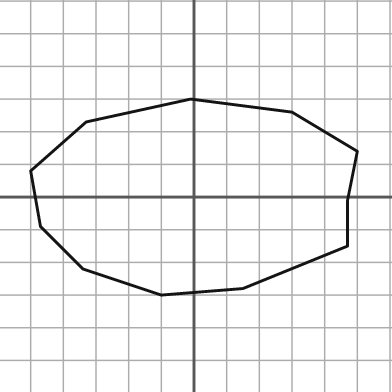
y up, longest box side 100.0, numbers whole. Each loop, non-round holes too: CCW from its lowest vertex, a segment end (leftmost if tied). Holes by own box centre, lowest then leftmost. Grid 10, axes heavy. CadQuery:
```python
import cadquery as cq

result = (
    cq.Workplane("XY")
    .moveTo(-10.0, -30.0)
    .lineTo(15.0, -28.0)
    .lineTo(47.0, -15.0)
    .lineTo(47.0, -1.0)
    .lineTo(50.0, 14.0)
    .lineTo(30.0, 26.0)
    .lineTo(-1.0, 30.0)
    .lineTo(-33.0, 23.0)
    .lineTo(-50.0, 8.0)
    .lineTo(-47.0, -9.0)
    .lineTo(-34.0, -22.0)
    .close()
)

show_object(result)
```